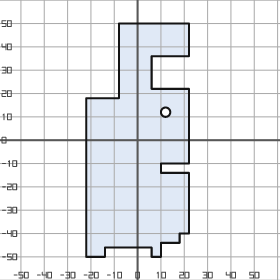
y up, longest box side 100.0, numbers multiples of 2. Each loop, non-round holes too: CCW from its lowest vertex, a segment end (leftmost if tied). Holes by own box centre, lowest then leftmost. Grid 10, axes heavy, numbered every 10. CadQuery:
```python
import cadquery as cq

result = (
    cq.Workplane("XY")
    .moveTo(-22.0, -50.0)
    .lineTo(-14.0, -50.0)
    .lineTo(-14.0, -46.0)
    .lineTo(6.0, -46.0)
    .lineTo(6.0, -50.0)
    .lineTo(10.0, -50.0)
    .lineTo(10.0, -44.0)
    .lineTo(18.0, -44.0)
    .lineTo(18.0, -40.0)
    .lineTo(22.0, -40.0)
    .lineTo(22.0, -14.0)
    .lineTo(10.0, -14.0)
    .lineTo(10.0, -10.0)
    .lineTo(22.0, -10.0)
    .lineTo(22.0, 22.0)
    .lineTo(6.0, 22.0)
    .lineTo(6.0, 36.0)
    .lineTo(22.0, 36.0)
    .lineTo(22.0, 50.0)
    .lineTo(-8.0, 50.0)
    .lineTo(-8.0, 18.0)
    .lineTo(-22.0, 18.0)
    .close()
    .moveTo(12.0, 12.0)
    .circle(2.0)
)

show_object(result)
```